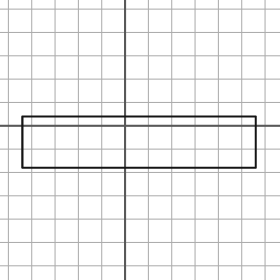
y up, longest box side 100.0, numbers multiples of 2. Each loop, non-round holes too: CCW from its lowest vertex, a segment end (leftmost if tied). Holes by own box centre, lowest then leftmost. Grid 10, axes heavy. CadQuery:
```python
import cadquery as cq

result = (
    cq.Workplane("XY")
    .moveTo(-44.0, -18.0)
    .lineTo(56.0, -18.0)
    .lineTo(56.0, 4.0)
    .lineTo(-44.0, 4.0)
    .close()
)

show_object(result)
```